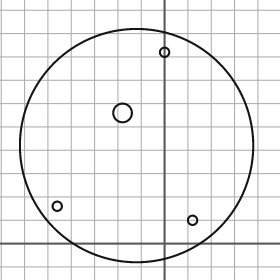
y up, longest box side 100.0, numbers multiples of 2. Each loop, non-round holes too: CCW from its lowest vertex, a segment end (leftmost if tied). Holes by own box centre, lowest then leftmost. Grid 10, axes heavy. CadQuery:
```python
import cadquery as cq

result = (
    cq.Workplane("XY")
    .moveTo(-12.0, 42.0)
    .circle(50.0)
    .moveTo(12.0, 10.0)
    .circle(2.0)
    .moveTo(-46.0, 16.0)
    .circle(2.0)
    .moveTo(-18.0, 56.0)
    .circle(4.0)
    .moveTo(0.0, 82.0)
    .circle(2.0)
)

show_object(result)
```